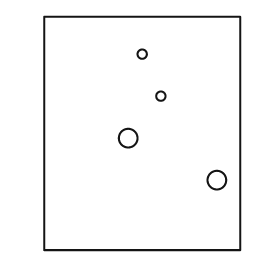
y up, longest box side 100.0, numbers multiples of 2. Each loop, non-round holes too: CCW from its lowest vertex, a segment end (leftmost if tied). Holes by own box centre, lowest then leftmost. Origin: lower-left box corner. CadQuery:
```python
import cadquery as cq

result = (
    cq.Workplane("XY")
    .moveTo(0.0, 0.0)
    .lineTo(84.0, 0.0)
    .lineTo(84.0, 100.0)
    .lineTo(0.0, 100.0)
    .close()
    .moveTo(74.0, 30.0)
    .circle(4.0)
    .moveTo(36.0, 48.0)
    .circle(4.0)
    .moveTo(50.0, 66.0)
    .circle(2.0)
    .moveTo(42.0, 84.0)
    .circle(2.0)
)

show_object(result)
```